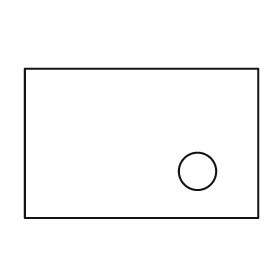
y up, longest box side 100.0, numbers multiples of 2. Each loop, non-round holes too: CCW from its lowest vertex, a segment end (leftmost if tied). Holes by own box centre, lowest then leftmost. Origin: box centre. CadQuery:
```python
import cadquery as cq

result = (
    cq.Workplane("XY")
    .moveTo(-50.0, -32.0)
    .lineTo(50.0, -32.0)
    .lineTo(50.0, 32.0)
    .lineTo(-50.0, 32.0)
    .close()
    .moveTo(24.0, -12.0)
    .circle(8.0)
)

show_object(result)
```